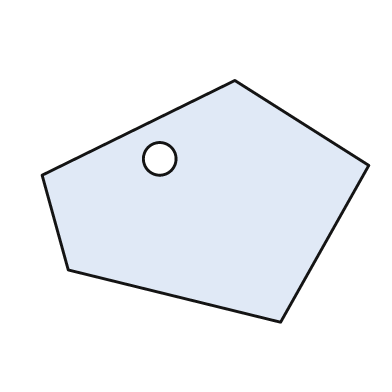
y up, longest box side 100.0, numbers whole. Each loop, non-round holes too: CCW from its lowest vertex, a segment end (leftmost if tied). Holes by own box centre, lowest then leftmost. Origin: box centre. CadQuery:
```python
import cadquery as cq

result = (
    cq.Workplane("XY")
    .moveTo(23.0, -37.0)
    .lineTo(50.0, 11.0)
    .lineTo(9.0, 37.0)
    .lineTo(-50.0, 8.0)
    .lineTo(-42.0, -21.0)
    .close()
    .moveTo(-14.0, 13.0)
    .circle(5.0)
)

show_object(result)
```